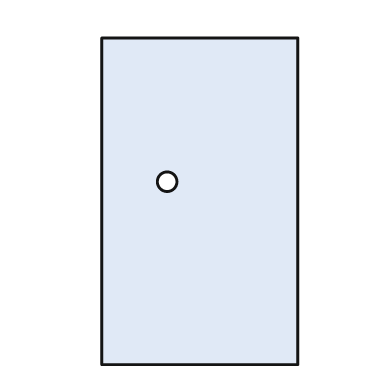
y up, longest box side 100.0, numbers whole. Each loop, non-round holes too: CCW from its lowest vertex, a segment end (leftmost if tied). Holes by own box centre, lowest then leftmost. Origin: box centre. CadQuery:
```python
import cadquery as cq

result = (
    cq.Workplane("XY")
    .moveTo(-30.0, -50.0)
    .lineTo(30.0, -50.0)
    .lineTo(30.0, 50.0)
    .lineTo(-30.0, 50.0)
    .close()
    .moveTo(-10.0, 6.0)
    .circle(3.0)
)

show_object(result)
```